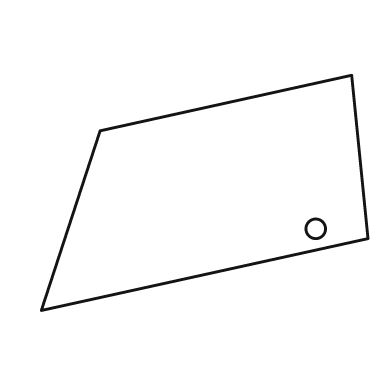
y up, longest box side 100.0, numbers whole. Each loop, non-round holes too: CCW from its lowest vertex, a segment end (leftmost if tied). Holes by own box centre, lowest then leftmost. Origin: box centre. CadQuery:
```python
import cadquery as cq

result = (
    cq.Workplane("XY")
    .moveTo(-50.0, -36.0)
    .lineTo(50.0, -14.0)
    .lineTo(45.0, 36.0)
    .lineTo(-32.0, 19.0)
    .close()
    .moveTo(34.0, -11.0)
    .circle(3.0)
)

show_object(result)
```